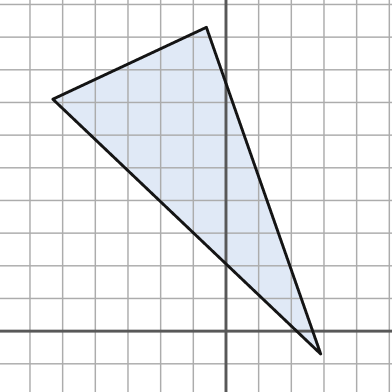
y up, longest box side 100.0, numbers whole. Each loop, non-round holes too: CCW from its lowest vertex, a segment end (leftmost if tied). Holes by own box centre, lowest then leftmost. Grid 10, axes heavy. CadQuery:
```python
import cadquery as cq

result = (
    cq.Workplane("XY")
    .moveTo(29.0, -7.0)
    .lineTo(-6.0, 93.0)
    .lineTo(-53.0, 71.0)
    .close()
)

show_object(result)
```